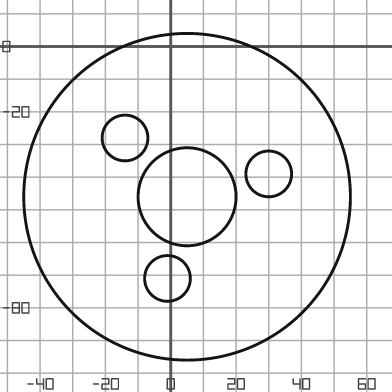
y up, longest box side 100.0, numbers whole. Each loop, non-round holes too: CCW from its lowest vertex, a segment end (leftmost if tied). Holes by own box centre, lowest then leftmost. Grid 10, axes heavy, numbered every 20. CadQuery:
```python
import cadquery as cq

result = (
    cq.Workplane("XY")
    .moveTo(5.0, -46.0)
    .circle(50.0)
    .moveTo(-1.0, -71.0)
    .circle(7.0)
    .moveTo(5.0, -46.0)
    .circle(15.0)
    .moveTo(30.0, -39.0)
    .circle(7.0)
    .moveTo(-14.0, -28.0)
    .circle(7.0)
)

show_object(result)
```